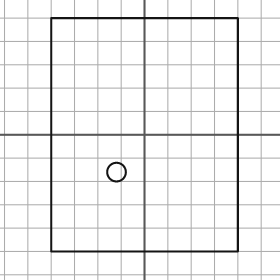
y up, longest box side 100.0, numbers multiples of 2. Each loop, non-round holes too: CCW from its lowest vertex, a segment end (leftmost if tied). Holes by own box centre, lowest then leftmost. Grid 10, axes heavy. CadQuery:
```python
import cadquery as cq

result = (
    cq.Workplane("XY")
    .moveTo(-40.0, -50.0)
    .lineTo(40.0, -50.0)
    .lineTo(40.0, 50.0)
    .lineTo(-40.0, 50.0)
    .close()
    .moveTo(-12.0, -16.0)
    .circle(4.0)
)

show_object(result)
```